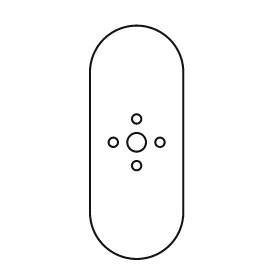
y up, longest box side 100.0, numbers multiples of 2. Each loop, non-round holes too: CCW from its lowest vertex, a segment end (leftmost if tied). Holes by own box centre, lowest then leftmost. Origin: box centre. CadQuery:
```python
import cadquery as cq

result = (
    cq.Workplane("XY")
    .moveTo(-20.0, -30.0)
    .threePointArc((0.0, -50.0), (20.0, -30.0))
    .lineTo(20.0, 30.0)
    .threePointArc((0.0, 50.0), (-20.0, 30.0))
    .close()
    .moveTo(0.0, -10.0)
    .circle(2.0)
    .moveTo(-10.0, 0.0)
    .circle(2.0)
    .moveTo(0.0, 0.0)
    .circle(4.0)
    .moveTo(10.0, 0.0)
    .circle(2.0)
    .moveTo(0.0, 10.0)
    .circle(2.0)
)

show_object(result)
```